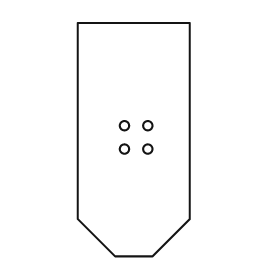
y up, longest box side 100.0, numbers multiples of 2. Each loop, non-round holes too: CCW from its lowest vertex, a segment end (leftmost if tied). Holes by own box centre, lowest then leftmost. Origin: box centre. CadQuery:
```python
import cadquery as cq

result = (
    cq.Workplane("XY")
    .moveTo(-8.0, -50.0)
    .lineTo(8.0, -50.0)
    .lineTo(24.0, -34.0)
    .lineTo(24.0, 50.0)
    .lineTo(-24.0, 50.0)
    .lineTo(-24.0, -34.0)
    .close()
    .moveTo(-4.0, -4.0)
    .circle(2.0)
    .moveTo(6.0, -4.0)
    .circle(2.0)
    .moveTo(-4.0, 6.0)
    .circle(2.0)
    .moveTo(6.0, 6.0)
    .circle(2.0)
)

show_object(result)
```